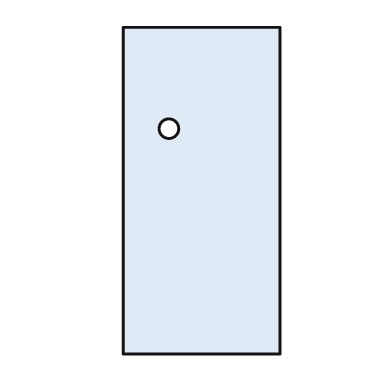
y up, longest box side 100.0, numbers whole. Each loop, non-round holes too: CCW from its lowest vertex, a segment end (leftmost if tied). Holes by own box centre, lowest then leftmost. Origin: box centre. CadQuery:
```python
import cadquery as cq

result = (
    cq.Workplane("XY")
    .moveTo(-24.0, -50.0)
    .lineTo(24.0, -50.0)
    .lineTo(24.0, 50.0)
    .lineTo(-24.0, 50.0)
    .close()
    .moveTo(-10.0, 19.0)
    .circle(3.0)
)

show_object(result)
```